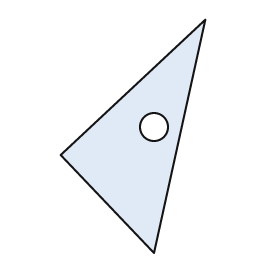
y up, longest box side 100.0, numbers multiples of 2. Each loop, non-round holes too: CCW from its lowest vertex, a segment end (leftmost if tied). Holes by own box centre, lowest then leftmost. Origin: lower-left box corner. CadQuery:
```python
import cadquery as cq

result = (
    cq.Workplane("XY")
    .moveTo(40.0, 0.0)
    .lineTo(62.0, 100.0)
    .lineTo(0.0, 42.0)
    .close()
    .moveTo(40.0, 54.0)
    .circle(6.0)
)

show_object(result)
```